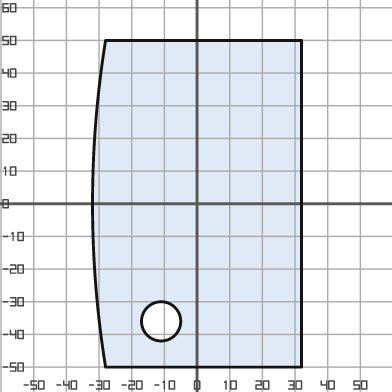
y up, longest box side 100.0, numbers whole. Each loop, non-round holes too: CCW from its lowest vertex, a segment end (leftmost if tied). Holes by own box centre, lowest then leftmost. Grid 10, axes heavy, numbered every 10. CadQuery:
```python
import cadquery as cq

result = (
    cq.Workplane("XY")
    .moveTo(-28.0, -50.0)
    .lineTo(32.0, -50.0)
    .lineTo(32.0, 50.0)
    .lineTo(-28.0, 50.0)
    .threePointArc((-32.0, 0.0), (-28.0, -50.0))
    .close()
    .moveTo(-11.0, -36.0)
    .circle(6.0)
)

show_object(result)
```